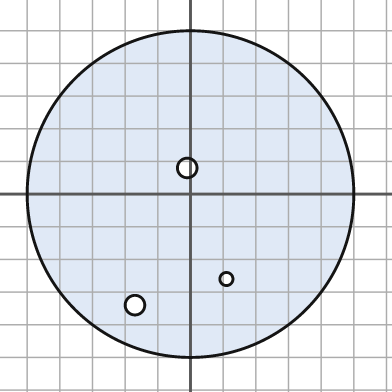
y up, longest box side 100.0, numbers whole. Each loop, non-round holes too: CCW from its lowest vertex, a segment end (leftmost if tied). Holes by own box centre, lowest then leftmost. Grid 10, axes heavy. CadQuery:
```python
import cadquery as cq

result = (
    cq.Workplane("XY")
    .moveTo(0.0, 0.0)
    .circle(50.0)
    .moveTo(-17.0, -34.0)
    .circle(3.0)
    .moveTo(11.0, -26.0)
    .circle(2.0)
    .moveTo(-1.0, 8.0)
    .circle(3.0)
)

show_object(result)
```